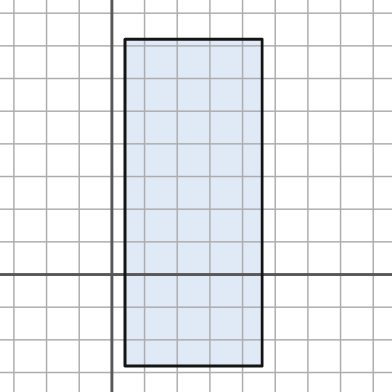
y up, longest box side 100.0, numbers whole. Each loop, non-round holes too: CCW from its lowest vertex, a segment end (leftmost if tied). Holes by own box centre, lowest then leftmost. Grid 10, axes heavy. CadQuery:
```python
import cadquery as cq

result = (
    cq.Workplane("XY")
    .moveTo(4.0, -28.0)
    .lineTo(46.0, -28.0)
    .lineTo(46.0, 72.0)
    .lineTo(4.0, 72.0)
    .close()
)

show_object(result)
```